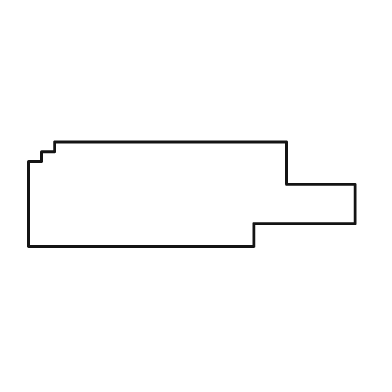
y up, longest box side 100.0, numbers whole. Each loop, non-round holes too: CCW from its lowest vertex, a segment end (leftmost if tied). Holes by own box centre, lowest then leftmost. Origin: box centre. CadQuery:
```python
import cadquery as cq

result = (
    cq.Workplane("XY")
    .moveTo(-50.0, -16.0)
    .lineTo(19.0, -16.0)
    .lineTo(19.0, -9.0)
    .lineTo(50.0, -9.0)
    .lineTo(50.0, 3.0)
    .lineTo(29.0, 3.0)
    .lineTo(29.0, 16.0)
    .lineTo(-42.0, 16.0)
    .lineTo(-42.0, 13.0)
    .lineTo(-46.0, 13.0)
    .lineTo(-46.0, 10.0)
    .lineTo(-50.0, 10.0)
    .close()
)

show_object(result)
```